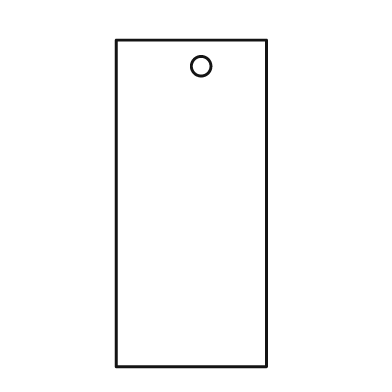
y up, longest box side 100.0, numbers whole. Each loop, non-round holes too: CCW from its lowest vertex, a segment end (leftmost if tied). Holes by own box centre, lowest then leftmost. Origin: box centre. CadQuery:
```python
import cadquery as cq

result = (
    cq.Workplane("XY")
    .moveTo(-23.0, -50.0)
    .lineTo(23.0, -50.0)
    .lineTo(23.0, 50.0)
    .lineTo(-23.0, 50.0)
    .close()
    .moveTo(3.0, 42.0)
    .circle(3.0)
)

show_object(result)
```